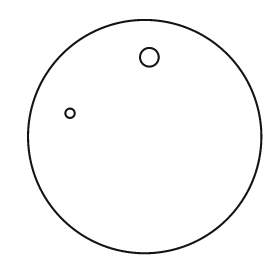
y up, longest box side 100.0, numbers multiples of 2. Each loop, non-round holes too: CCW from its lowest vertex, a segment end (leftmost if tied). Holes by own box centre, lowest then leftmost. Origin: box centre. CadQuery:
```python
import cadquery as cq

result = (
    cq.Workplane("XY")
    .moveTo(0.0, 0.0)
    .circle(50.0)
    .moveTo(-32.0, 10.0)
    .circle(2.0)
    .moveTo(2.0, 34.0)
    .circle(4.0)
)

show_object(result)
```